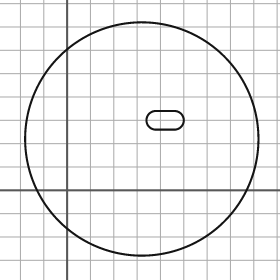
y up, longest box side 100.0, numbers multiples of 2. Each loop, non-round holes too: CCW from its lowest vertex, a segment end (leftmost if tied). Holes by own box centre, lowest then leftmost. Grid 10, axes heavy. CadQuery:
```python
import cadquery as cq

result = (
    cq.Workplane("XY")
    .moveTo(32.0, 22.0)
    .circle(50.0)
    .moveTo(38.0, 26.0)
    .lineTo(46.0, 26.0)
    .threePointArc((50.0, 30.0), (46.0, 34.0))
    .lineTo(38.0, 34.0)
    .threePointArc((34.0, 30.0), (38.0, 26.0))
    .close()
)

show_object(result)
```